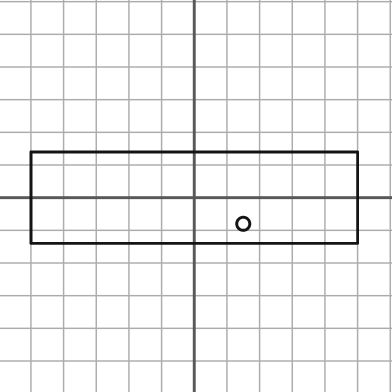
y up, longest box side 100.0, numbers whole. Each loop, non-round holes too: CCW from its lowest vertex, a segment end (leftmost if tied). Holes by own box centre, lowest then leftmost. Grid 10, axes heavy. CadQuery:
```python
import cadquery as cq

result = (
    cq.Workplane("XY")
    .moveTo(-50.0, -14.0)
    .lineTo(50.0, -14.0)
    .lineTo(50.0, 14.0)
    .lineTo(-50.0, 14.0)
    .close()
    .moveTo(15.0, -8.0)
    .circle(2.0)
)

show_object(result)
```